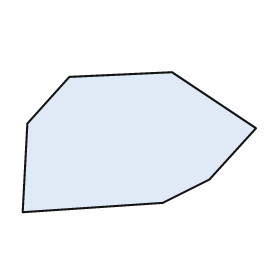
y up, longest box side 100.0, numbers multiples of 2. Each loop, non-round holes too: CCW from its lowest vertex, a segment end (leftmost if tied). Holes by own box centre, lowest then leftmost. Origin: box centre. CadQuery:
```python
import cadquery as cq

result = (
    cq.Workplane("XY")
    .moveTo(-50.0, -30.0)
    .lineTo(10.0, -26.0)
    .lineTo(30.0, -16.0)
    .lineTo(50.0, 6.0)
    .lineTo(14.0, 30.0)
    .lineTo(-30.0, 28.0)
    .lineTo(-48.0, 8.0)
    .close()
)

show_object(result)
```